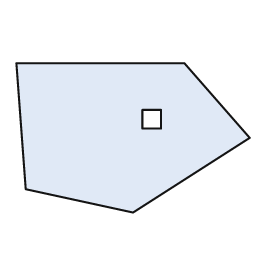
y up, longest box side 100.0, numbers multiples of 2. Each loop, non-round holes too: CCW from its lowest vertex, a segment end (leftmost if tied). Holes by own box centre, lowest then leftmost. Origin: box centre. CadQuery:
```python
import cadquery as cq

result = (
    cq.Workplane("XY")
    .moveTo(0.0, -32.0)
    .lineTo(50.0, 0.0)
    .lineTo(22.0, 32.0)
    .lineTo(-50.0, 32.0)
    .lineTo(-46.0, -22.0)
    .close()
    .moveTo(4.0, 4.0)
    .lineTo(12.0, 4.0)
    .lineTo(12.0, 12.0)
    .lineTo(4.0, 12.0)
    .close()
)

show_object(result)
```